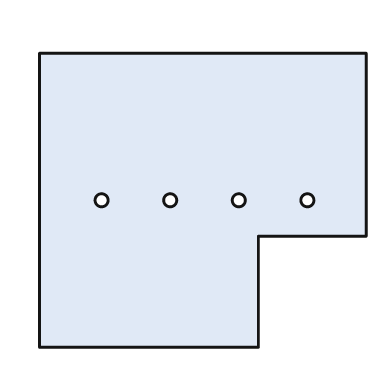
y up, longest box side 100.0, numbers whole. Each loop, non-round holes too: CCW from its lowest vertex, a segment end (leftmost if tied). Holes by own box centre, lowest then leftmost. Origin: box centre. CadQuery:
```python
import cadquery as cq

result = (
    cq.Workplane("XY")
    .moveTo(-50.0, -45.0)
    .lineTo(17.0, -45.0)
    .lineTo(17.0, -11.0)
    .lineTo(50.0, -11.0)
    .lineTo(50.0, 45.0)
    .lineTo(-50.0, 45.0)
    .close()
    .moveTo(-31.0, 0.0)
    .circle(2.0)
    .moveTo(-10.0, 0.0)
    .circle(2.0)
    .moveTo(11.0, 0.0)
    .circle(2.0)
    .moveTo(32.0, 0.0)
    .circle(2.0)
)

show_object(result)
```